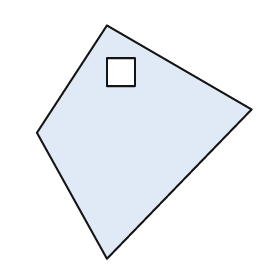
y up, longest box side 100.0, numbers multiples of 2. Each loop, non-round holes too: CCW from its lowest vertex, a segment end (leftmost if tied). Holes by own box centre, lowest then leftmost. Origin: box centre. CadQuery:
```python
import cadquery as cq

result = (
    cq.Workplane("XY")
    .moveTo(-16.0, -50.0)
    .lineTo(46.0, 14.0)
    .lineTo(-16.0, 50.0)
    .lineTo(-46.0, 4.0)
    .close()
    .moveTo(-16.0, 24.0)
    .lineTo(-4.0, 24.0)
    .lineTo(-4.0, 36.0)
    .lineTo(-16.0, 36.0)
    .close()
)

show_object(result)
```